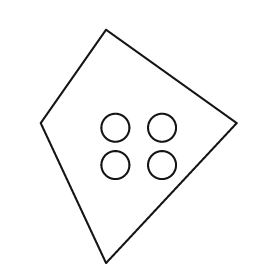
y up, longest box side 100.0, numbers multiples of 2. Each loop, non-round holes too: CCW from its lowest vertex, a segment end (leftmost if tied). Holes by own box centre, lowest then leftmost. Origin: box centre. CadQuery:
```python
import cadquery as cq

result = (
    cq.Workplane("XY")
    .moveTo(-14.0, -50.0)
    .lineTo(42.0, 10.0)
    .lineTo(-14.0, 50.0)
    .lineTo(-42.0, 10.0)
    .close()
    .moveTo(-10.0, -8.0)
    .circle(6.0)
    .moveTo(10.0, -8.0)
    .circle(6.0)
    .moveTo(-10.0, 8.0)
    .circle(6.0)
    .moveTo(10.0, 8.0)
    .circle(6.0)
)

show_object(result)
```